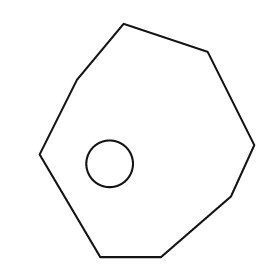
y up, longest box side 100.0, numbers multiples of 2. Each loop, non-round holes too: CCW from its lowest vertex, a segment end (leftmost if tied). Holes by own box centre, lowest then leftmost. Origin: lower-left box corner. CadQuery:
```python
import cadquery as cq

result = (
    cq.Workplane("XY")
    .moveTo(26.0, 0.0)
    .lineTo(52.0, 0.0)
    .lineTo(82.0, 26.0)
    .lineTo(92.0, 48.0)
    .lineTo(72.0, 88.0)
    .lineTo(36.0, 100.0)
    .lineTo(16.0, 76.0)
    .lineTo(0.0, 44.0)
    .close()
    .moveTo(30.0, 40.0)
    .circle(10.0)
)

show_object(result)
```